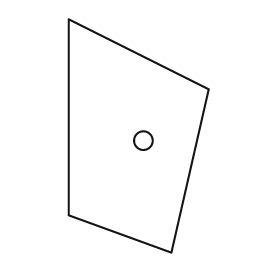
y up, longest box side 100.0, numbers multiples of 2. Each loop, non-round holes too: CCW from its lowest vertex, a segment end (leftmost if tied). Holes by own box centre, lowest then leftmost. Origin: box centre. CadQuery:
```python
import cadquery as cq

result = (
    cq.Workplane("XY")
    .moveTo(14.0, -50.0)
    .lineTo(30.0, 20.0)
    .lineTo(-30.0, 50.0)
    .lineTo(-30.0, -34.0)
    .close()
    .moveTo(2.0, -2.0)
    .circle(4.0)
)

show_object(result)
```